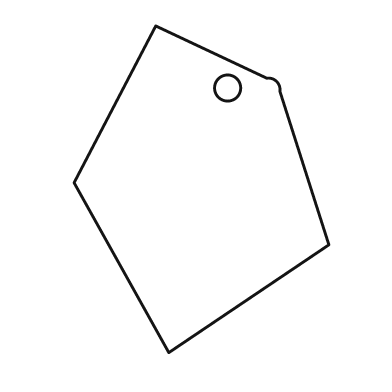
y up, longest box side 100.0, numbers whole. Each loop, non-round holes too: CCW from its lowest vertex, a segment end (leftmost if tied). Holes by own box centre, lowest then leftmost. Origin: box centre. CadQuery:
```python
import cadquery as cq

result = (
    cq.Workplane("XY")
    .moveTo(-10.0, -50.0)
    .lineTo(39.0, -17.0)
    .lineTo(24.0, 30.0)
    .threePointArc((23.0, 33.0), (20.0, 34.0))
    .lineTo(-14.0, 50.0)
    .lineTo(-39.0, 2.0)
    .close()
    .moveTo(8.0, 31.0)
    .circle(4.0)
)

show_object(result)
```